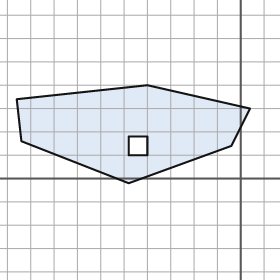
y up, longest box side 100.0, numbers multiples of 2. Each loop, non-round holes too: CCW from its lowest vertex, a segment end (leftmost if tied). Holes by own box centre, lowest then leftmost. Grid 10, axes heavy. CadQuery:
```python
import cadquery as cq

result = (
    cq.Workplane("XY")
    .moveTo(-48.0, -2.0)
    .lineTo(-4.0, 14.0)
    .lineTo(4.0, 30.0)
    .lineTo(-40.0, 40.0)
    .lineTo(-96.0, 34.0)
    .lineTo(-94.0, 16.0)
    .close()
    .moveTo(-48.0, 10.0)
    .lineTo(-40.0, 10.0)
    .lineTo(-40.0, 18.0)
    .lineTo(-48.0, 18.0)
    .close()
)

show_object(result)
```